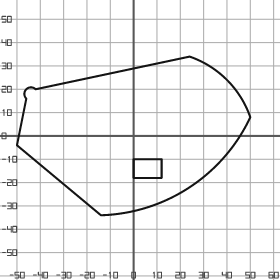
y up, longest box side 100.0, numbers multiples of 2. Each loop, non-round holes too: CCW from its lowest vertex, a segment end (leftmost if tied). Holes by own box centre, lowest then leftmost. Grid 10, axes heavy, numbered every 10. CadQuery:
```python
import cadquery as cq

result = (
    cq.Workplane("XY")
    .moveTo(-14.0, -34.0)
    .threePointArc((24.0, -22.0), (50.0, 8.0))
    .threePointArc((40.0, 24.0), (24.0, 34.0))
    .lineTo(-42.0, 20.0)
    .threePointArc((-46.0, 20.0), (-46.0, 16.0))
    .lineTo(-50.0, -4.0)
    .close()
    .moveTo(0.0, -18.0)
    .lineTo(12.0, -18.0)
    .lineTo(12.0, -10.0)
    .lineTo(0.0, -10.0)
    .close()
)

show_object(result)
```